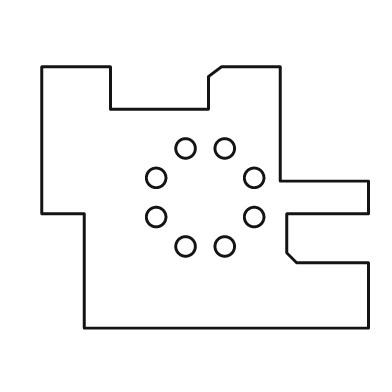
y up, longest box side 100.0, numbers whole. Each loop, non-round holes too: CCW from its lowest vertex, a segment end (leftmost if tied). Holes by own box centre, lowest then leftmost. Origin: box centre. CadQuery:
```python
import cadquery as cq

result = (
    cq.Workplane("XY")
    .moveTo(-37.0, -40.0)
    .lineTo(50.0, -40.0)
    .lineTo(50.0, -20.0)
    .lineTo(28.0, -20.0)
    .lineTo(25.0, -17.0)
    .lineTo(25.0, -5.0)
    .lineTo(50.0, -5.0)
    .lineTo(50.0, 5.0)
    .lineTo(23.0, 5.0)
    .lineTo(23.0, 40.0)
    .lineTo(5.0, 40.0)
    .lineTo(1.0, 37.0)
    .lineTo(1.0, 27.0)
    .lineTo(-29.0, 27.0)
    .lineTo(-29.0, 40.0)
    .lineTo(-50.0, 40.0)
    .lineTo(-50.0, -5.0)
    .lineTo(-37.0, -5.0)
    .close()
    .moveTo(-6.0, -15.0)
    .circle(3.0)
    .moveTo(6.0, -15.0)
    .circle(3.0)
    .moveTo(-15.0, -6.0)
    .circle(3.0)
    .moveTo(15.0, -6.0)
    .circle(3.0)
    .moveTo(-15.0, 6.0)
    .circle(3.0)
    .moveTo(15.0, 6.0)
    .circle(3.0)
    .moveTo(-6.0, 15.0)
    .circle(3.0)
    .moveTo(6.0, 15.0)
    .circle(3.0)
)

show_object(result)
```